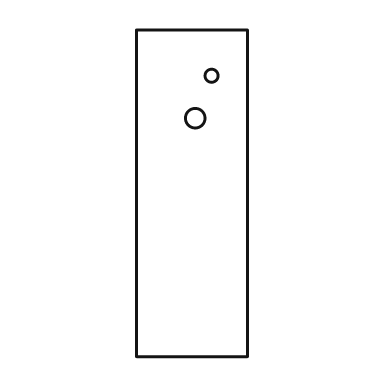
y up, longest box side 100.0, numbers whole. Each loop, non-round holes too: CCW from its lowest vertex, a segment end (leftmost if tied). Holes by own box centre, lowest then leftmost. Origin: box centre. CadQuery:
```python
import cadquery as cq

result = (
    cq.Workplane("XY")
    .moveTo(-17.0, -50.0)
    .lineTo(17.0, -50.0)
    .lineTo(17.0, 50.0)
    .lineTo(-17.0, 50.0)
    .close()
    .moveTo(1.0, 23.0)
    .circle(3.0)
    .moveTo(6.0, 36.0)
    .circle(2.0)
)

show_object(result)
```